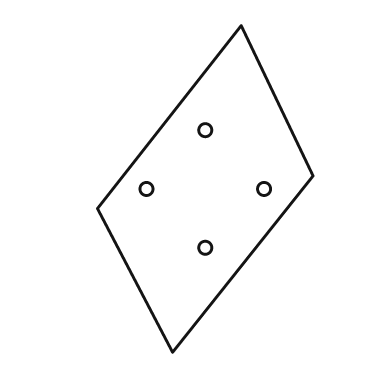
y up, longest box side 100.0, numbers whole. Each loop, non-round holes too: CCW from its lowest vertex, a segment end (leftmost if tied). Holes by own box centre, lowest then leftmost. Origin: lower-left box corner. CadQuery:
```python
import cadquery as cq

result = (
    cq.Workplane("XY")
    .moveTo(23.0, 0.0)
    .lineTo(66.0, 54.0)
    .lineTo(44.0, 100.0)
    .lineTo(0.0, 44.0)
    .close()
    .moveTo(33.0, 32.0)
    .circle(2.0)
    .moveTo(15.0, 50.0)
    .circle(2.0)
    .moveTo(51.0, 50.0)
    .circle(2.0)
    .moveTo(33.0, 68.0)
    .circle(2.0)
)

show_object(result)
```